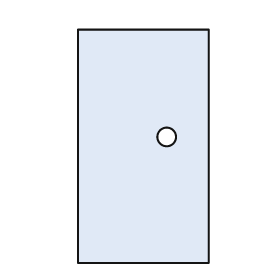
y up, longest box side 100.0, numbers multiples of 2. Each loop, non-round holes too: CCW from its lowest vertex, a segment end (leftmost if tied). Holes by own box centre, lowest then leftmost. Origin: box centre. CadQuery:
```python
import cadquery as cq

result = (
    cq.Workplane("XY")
    .moveTo(-28.0, -50.0)
    .lineTo(28.0, -50.0)
    .lineTo(28.0, 50.0)
    .lineTo(-28.0, 50.0)
    .close()
    .moveTo(10.0, 4.0)
    .circle(4.0)
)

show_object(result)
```